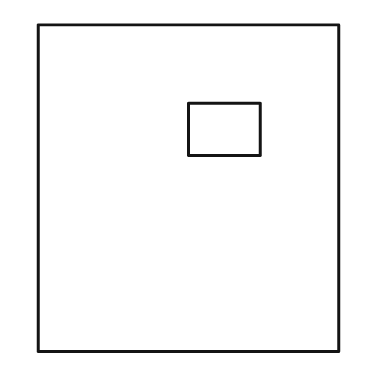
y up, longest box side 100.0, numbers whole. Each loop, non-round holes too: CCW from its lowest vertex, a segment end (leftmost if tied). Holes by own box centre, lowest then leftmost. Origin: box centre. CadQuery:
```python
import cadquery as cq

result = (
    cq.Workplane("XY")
    .moveTo(-46.0, -50.0)
    .lineTo(46.0, -50.0)
    .lineTo(46.0, 50.0)
    .lineTo(-46.0, 50.0)
    .close()
    .moveTo(0.0, 10.0)
    .lineTo(22.0, 10.0)
    .lineTo(22.0, 26.0)
    .lineTo(0.0, 26.0)
    .close()
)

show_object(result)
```